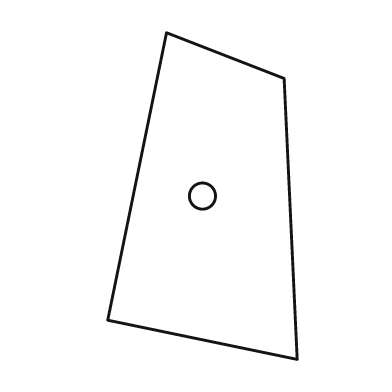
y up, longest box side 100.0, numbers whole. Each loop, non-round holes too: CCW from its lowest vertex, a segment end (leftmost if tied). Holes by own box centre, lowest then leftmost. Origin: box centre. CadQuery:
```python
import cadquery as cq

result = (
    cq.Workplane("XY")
    .moveTo(29.0, -50.0)
    .lineTo(25.0, 36.0)
    .lineTo(-11.0, 50.0)
    .lineTo(-29.0, -38.0)
    .close()
    .moveTo(0.0, 0.0)
    .circle(4.0)
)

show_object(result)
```